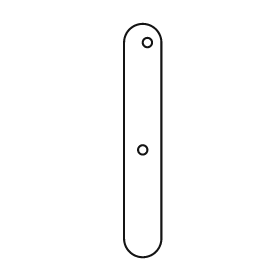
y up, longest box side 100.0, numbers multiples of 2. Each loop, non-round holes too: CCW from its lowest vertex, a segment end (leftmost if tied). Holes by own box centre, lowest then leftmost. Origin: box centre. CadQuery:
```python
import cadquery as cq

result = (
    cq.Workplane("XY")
    .moveTo(-8.0, -42.0)
    .threePointArc((0.0, -50.0), (8.0, -42.0))
    .lineTo(8.0, 42.0)
    .threePointArc((0.0, 50.0), (-8.0, 42.0))
    .close()
    .moveTo(0.0, -4.0)
    .circle(2.0)
    .moveTo(2.0, 42.0)
    .circle(2.0)
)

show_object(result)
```